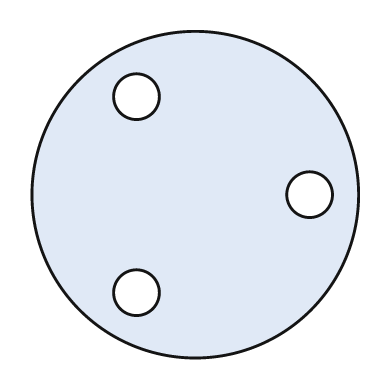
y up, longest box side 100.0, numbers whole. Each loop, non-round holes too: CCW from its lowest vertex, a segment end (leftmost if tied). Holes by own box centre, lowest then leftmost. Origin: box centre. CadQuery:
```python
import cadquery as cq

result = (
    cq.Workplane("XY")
    .moveTo(0.0, 0.0)
    .circle(50.0)
    .moveTo(-18.0, -30.0)
    .circle(7.0)
    .moveTo(35.0, 0.0)
    .circle(7.0)
    .moveTo(-18.0, 30.0)
    .circle(7.0)
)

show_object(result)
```